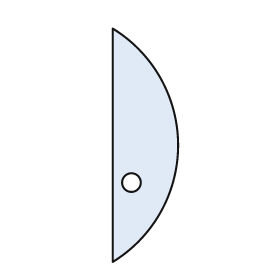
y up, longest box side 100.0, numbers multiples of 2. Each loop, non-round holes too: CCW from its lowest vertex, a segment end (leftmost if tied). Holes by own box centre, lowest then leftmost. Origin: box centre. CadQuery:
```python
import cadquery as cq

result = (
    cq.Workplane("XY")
    .moveTo(-14.0, -50.0)
    .threePointArc((14.0, 0.0), (-14.0, 50.0))
    .close()
    .moveTo(-6.0, -16.0)
    .circle(4.0)
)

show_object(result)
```